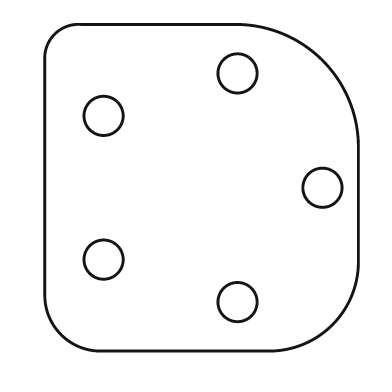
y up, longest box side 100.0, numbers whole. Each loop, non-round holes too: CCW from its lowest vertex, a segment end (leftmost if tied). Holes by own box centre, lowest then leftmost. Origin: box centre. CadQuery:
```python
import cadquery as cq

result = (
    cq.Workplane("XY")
    .moveTo(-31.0, -50.0)
    .lineTo(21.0, -50.0)
    .threePointArc((40.0, -42.0), (48.0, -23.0))
    .lineTo(48.0, 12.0)
    .threePointArc((37.0, 39.0), (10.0, 50.0))
    .lineTo(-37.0, 50.0)
    .threePointArc((-45.0, 47.0), (-48.0, 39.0))
    .lineTo(-48.0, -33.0)
    .threePointArc((-43.0, -45.0), (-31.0, -50.0))
    .close()
    .moveTo(11.0, -35.0)
    .circle(6.0)
    .moveTo(-30.0, -22.0)
    .circle(6.0)
    .moveTo(37.0, 0.0)
    .circle(6.0)
    .moveTo(-30.0, 22.0)
    .circle(6.0)
    .moveTo(11.0, 35.0)
    .circle(6.0)
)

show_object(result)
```